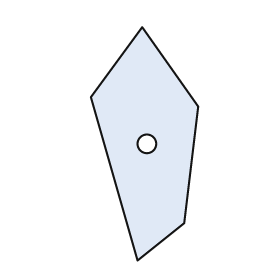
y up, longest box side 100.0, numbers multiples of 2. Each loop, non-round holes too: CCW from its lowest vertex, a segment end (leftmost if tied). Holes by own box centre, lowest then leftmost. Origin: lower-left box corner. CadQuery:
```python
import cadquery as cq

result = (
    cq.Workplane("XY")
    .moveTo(20.0, 0.0)
    .lineTo(40.0, 16.0)
    .lineTo(46.0, 66.0)
    .lineTo(22.0, 100.0)
    .lineTo(0.0, 70.0)
    .close()
    .moveTo(24.0, 50.0)
    .circle(4.0)
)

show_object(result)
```